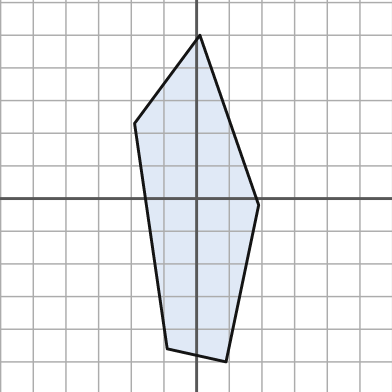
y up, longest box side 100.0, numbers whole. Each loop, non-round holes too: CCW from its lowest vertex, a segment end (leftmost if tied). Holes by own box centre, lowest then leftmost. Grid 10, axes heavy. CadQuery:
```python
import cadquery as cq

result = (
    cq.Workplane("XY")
    .moveTo(9.0, -50.0)
    .lineTo(19.0, -2.0)
    .lineTo(1.0, 50.0)
    .lineTo(-19.0, 23.0)
    .lineTo(-9.0, -46.0)
    .close()
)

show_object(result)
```